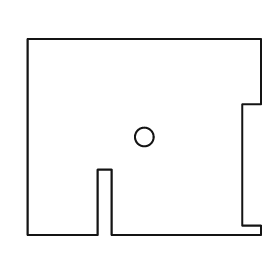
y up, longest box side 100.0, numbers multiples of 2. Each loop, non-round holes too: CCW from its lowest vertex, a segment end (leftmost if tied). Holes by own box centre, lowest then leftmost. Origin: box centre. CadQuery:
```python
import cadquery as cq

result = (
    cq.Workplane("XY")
    .moveTo(-50.0, -42.0)
    .lineTo(-20.0, -42.0)
    .lineTo(-20.0, -14.0)
    .lineTo(-14.0, -14.0)
    .lineTo(-14.0, -42.0)
    .lineTo(50.0, -42.0)
    .lineTo(50.0, -38.0)
    .lineTo(42.0, -38.0)
    .lineTo(42.0, 14.0)
    .lineTo(50.0, 14.0)
    .lineTo(50.0, 42.0)
    .lineTo(-50.0, 42.0)
    .close()
    .moveTo(0.0, 0.0)
    .circle(4.0)
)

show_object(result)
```